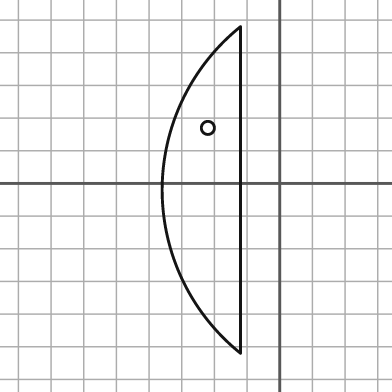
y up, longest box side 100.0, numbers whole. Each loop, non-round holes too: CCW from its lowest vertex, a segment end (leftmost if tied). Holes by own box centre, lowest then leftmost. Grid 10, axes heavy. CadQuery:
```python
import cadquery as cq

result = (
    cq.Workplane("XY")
    .moveTo(-12.0, -52.0)
    .lineTo(-12.0, 48.0)
    .threePointArc((-36.0, -2.0), (-12.0, -52.0))
    .close()
    .moveTo(-22.0, 17.0)
    .circle(2.0)
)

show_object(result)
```